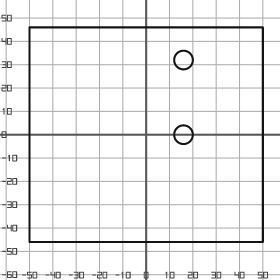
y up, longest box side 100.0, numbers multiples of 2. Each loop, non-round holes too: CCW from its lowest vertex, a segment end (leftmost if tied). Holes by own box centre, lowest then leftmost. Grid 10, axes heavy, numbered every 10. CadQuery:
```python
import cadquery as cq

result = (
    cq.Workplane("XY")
    .moveTo(-50.0, -46.0)
    .lineTo(50.0, -46.0)
    .lineTo(50.0, 46.0)
    .lineTo(-50.0, 46.0)
    .close()
    .moveTo(16.0, 0.0)
    .circle(4.0)
    .moveTo(16.0, 32.0)
    .circle(4.0)
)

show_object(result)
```